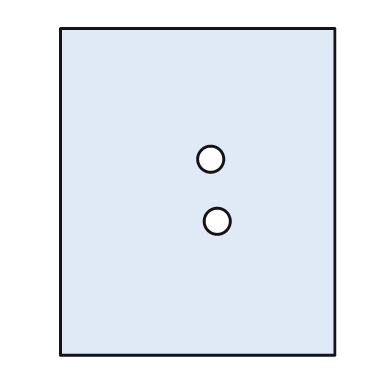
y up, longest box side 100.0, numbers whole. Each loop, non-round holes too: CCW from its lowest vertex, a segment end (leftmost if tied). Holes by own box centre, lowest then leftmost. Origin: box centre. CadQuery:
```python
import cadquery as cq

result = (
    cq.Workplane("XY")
    .moveTo(-42.0, -50.0)
    .lineTo(42.0, -50.0)
    .lineTo(42.0, 50.0)
    .lineTo(-42.0, 50.0)
    .close()
    .moveTo(6.0, -9.0)
    .circle(4.0)
    .moveTo(4.0, 10.0)
    .circle(4.0)
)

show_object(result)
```